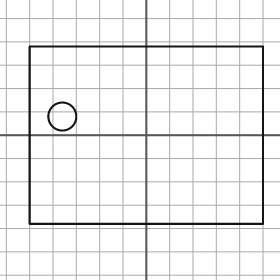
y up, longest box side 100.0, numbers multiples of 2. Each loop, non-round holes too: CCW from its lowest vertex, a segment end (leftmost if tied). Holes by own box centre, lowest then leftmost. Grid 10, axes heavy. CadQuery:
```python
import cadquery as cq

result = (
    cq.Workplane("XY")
    .moveTo(-50.0, -38.0)
    .lineTo(50.0, -38.0)
    .lineTo(50.0, 38.0)
    .lineTo(-50.0, 38.0)
    .close()
    .moveTo(-36.0, 8.0)
    .circle(6.0)
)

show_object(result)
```